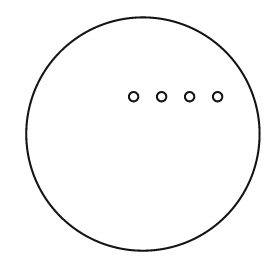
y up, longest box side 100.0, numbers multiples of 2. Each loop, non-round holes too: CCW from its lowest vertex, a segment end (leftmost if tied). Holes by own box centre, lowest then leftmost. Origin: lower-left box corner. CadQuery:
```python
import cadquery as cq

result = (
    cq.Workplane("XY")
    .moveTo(50.0, 50.0)
    .circle(50.0)
    .moveTo(46.0, 66.0)
    .circle(2.0)
    .moveTo(58.0, 66.0)
    .circle(2.0)
    .moveTo(70.0, 66.0)
    .circle(2.0)
    .moveTo(82.0, 66.0)
    .circle(2.0)
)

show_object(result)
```